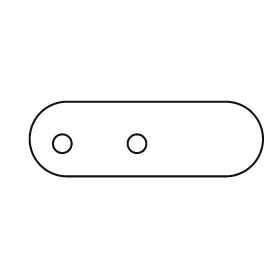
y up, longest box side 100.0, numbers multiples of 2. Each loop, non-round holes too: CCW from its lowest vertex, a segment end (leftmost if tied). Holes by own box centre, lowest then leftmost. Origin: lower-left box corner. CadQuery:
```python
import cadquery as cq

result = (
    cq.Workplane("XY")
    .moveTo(16.0, 0.0)
    .lineTo(84.0, 0.0)
    .threePointArc((100.0, 16.0), (84.0, 32.0))
    .lineTo(16.0, 32.0)
    .threePointArc((0.0, 16.0), (16.0, 0.0))
    .close()
    .moveTo(14.0, 14.0)
    .circle(4.0)
    .moveTo(46.0, 14.0)
    .circle(4.0)
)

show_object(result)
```